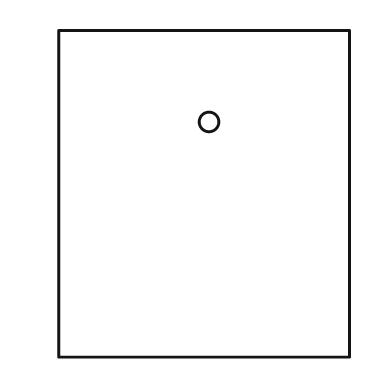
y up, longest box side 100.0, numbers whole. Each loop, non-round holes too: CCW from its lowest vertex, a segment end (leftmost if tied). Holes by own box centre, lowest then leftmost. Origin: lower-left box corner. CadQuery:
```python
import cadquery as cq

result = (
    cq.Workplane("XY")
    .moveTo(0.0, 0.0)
    .lineTo(89.0, 0.0)
    .lineTo(89.0, 100.0)
    .lineTo(0.0, 100.0)
    .close()
    .moveTo(46.0, 72.0)
    .circle(3.0)
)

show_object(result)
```